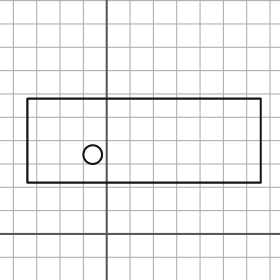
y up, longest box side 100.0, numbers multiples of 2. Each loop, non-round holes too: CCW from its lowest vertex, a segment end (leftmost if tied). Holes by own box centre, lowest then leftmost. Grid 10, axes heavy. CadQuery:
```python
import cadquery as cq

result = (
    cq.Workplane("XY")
    .moveTo(-34.0, 22.0)
    .lineTo(66.0, 22.0)
    .lineTo(66.0, 58.0)
    .lineTo(-34.0, 58.0)
    .close()
    .moveTo(-6.0, 34.0)
    .circle(4.0)
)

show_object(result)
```